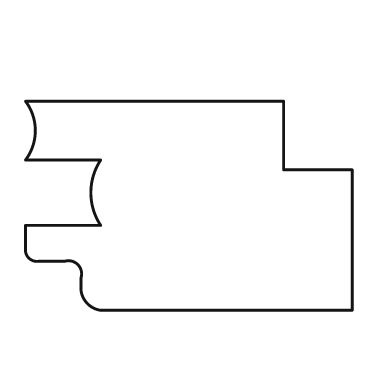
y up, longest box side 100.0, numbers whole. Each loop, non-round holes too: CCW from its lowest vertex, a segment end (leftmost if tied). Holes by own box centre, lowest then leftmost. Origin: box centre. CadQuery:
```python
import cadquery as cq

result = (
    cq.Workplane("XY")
    .moveTo(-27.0, -32.0)
    .lineTo(50.0, -32.0)
    .lineTo(50.0, 11.0)
    .lineTo(29.0, 11.0)
    .lineTo(29.0, 32.0)
    .lineTo(-50.0, 32.0)
    .threePointArc((-47.0, 23.0), (-50.0, 14.0))
    .lineTo(-27.0, 14.0)
    .threePointArc((-30.0, 4.0), (-27.0, -6.0))
    .lineTo(-50.0, -6.0)
    .lineTo(-50.0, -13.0)
    .threePointArc((-49.0, -16.0), (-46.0, -17.0))
    .lineTo(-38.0, -17.0)
    .threePointArc((-34.0, -18.0), (-33.0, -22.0))
    .lineTo(-33.0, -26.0)
    .threePointArc((-31.0, -30.0), (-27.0, -32.0))
    .close()
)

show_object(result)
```